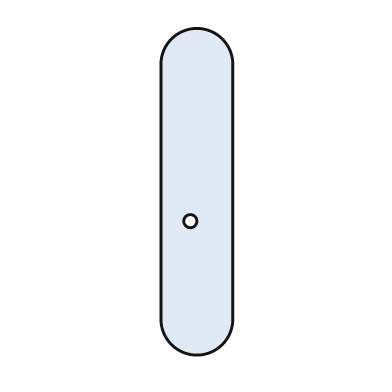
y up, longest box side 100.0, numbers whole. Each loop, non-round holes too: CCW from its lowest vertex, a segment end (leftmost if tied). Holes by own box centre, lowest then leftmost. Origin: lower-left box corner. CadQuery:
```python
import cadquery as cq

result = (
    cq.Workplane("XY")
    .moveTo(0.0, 11.0)
    .threePointArc((11.0, 0.0), (22.0, 11.0))
    .lineTo(22.0, 89.0)
    .threePointArc((11.0, 100.0), (0.0, 89.0))
    .close()
    .moveTo(9.0, 41.0)
    .circle(2.0)
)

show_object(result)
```